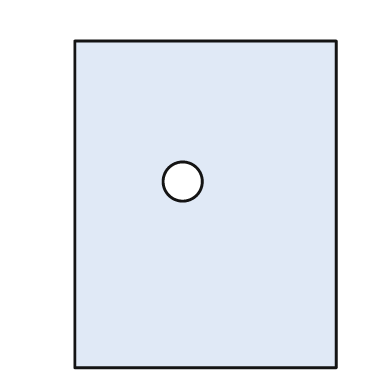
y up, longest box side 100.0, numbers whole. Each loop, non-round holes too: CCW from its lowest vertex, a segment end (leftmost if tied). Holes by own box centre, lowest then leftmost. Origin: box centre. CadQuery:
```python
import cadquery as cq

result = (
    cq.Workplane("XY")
    .moveTo(-40.0, -50.0)
    .lineTo(40.0, -50.0)
    .lineTo(40.0, 50.0)
    .lineTo(-40.0, 50.0)
    .close()
    .moveTo(-7.0, 7.0)
    .circle(6.0)
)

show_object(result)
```